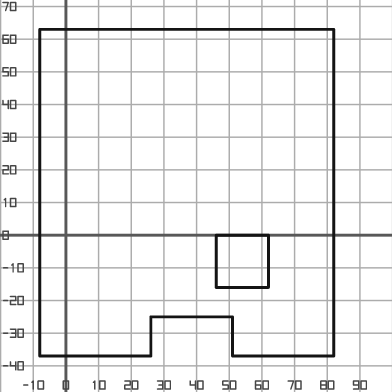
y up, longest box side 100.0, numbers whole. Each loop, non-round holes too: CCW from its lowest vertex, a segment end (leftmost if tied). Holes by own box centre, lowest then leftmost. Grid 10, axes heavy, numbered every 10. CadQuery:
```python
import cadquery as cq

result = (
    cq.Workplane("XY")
    .moveTo(-8.0, -37.0)
    .lineTo(26.0, -37.0)
    .lineTo(26.0, -25.0)
    .lineTo(51.0, -25.0)
    .lineTo(51.0, -37.0)
    .lineTo(82.0, -37.0)
    .lineTo(82.0, 63.0)
    .lineTo(-8.0, 63.0)
    .close()
    .moveTo(46.0, -16.0)
    .lineTo(62.0, -16.0)
    .lineTo(62.0, 0.0)
    .lineTo(46.0, 0.0)
    .close()
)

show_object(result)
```